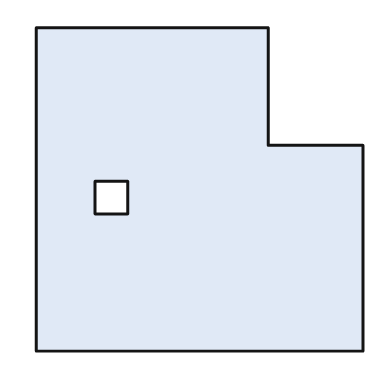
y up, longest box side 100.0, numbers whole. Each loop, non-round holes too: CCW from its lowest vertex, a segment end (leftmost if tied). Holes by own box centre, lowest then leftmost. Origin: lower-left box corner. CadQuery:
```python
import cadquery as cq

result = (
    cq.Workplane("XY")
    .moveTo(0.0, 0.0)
    .lineTo(100.0, 0.0)
    .lineTo(100.0, 63.0)
    .lineTo(71.0, 63.0)
    .lineTo(71.0, 99.0)
    .lineTo(0.0, 99.0)
    .close()
    .moveTo(18.0, 42.0)
    .lineTo(28.0, 42.0)
    .lineTo(28.0, 52.0)
    .lineTo(18.0, 52.0)
    .close()
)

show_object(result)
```